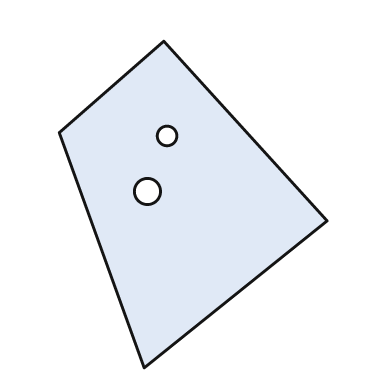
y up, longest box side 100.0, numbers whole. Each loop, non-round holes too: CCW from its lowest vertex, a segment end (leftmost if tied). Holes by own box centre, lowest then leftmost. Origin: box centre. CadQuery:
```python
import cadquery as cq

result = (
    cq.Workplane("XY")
    .moveTo(-15.0, -50.0)
    .lineTo(41.0, -5.0)
    .lineTo(-9.0, 50.0)
    .lineTo(-41.0, 22.0)
    .close()
    .moveTo(-14.0, 4.0)
    .circle(4.0)
    .moveTo(-8.0, 21.0)
    .circle(3.0)
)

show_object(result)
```